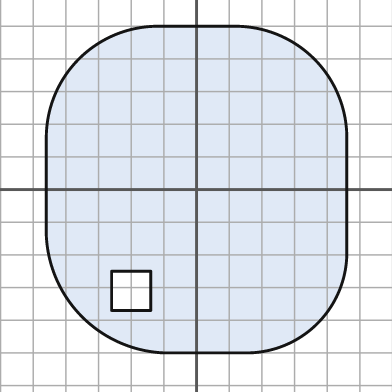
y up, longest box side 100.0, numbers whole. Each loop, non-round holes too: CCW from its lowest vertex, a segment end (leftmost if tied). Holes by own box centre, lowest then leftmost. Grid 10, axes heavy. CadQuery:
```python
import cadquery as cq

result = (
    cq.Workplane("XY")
    .moveTo(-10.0, -50.0)
    .lineTo(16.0, -50.0)
    .threePointArc((37.0, -41.0), (46.0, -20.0))
    .lineTo(46.0, 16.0)
    .threePointArc((36.0, 40.0), (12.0, 50.0))
    .lineTo(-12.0, 50.0)
    .threePointArc((-36.0, 40.0), (-46.0, 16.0))
    .lineTo(-46.0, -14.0)
    .threePointArc((-35.0, -39.0), (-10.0, -50.0))
    .close()
    .moveTo(-26.0, -37.0)
    .lineTo(-14.0, -37.0)
    .lineTo(-14.0, -25.0)
    .lineTo(-26.0, -25.0)
    .close()
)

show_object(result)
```